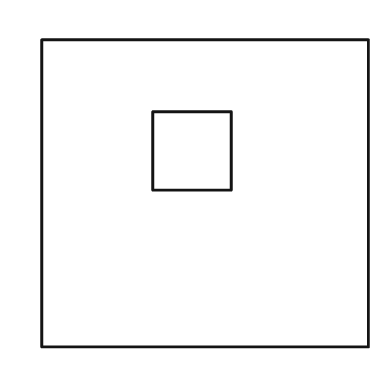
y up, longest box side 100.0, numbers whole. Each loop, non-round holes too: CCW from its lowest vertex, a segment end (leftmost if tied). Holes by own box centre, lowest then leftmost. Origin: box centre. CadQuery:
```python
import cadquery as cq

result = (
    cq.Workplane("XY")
    .moveTo(-50.0, -47.0)
    .lineTo(50.0, -47.0)
    .lineTo(50.0, 47.0)
    .lineTo(-50.0, 47.0)
    .close()
    .moveTo(-16.0, 1.0)
    .lineTo(8.0, 1.0)
    .lineTo(8.0, 25.0)
    .lineTo(-16.0, 25.0)
    .close()
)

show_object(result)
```